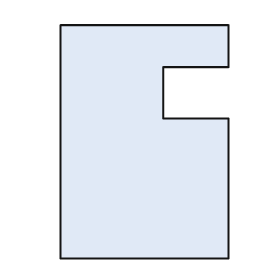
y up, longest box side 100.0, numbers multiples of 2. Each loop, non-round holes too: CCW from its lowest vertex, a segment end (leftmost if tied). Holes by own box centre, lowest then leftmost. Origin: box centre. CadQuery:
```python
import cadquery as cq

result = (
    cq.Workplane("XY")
    .moveTo(-36.0, -50.0)
    .lineTo(36.0, -50.0)
    .lineTo(36.0, 10.0)
    .lineTo(8.0, 10.0)
    .lineTo(8.0, 32.0)
    .lineTo(36.0, 32.0)
    .lineTo(36.0, 50.0)
    .lineTo(-36.0, 50.0)
    .close()
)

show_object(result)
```